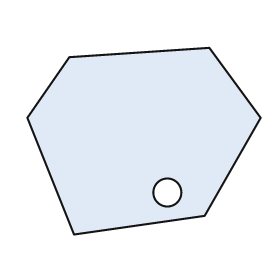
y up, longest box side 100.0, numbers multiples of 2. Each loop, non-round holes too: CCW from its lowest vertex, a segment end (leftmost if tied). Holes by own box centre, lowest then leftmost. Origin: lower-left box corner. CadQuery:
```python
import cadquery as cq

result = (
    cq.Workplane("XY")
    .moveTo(20.0, 0.0)
    .lineTo(76.0, 8.0)
    .lineTo(100.0, 50.0)
    .lineTo(78.0, 80.0)
    .lineTo(18.0, 76.0)
    .lineTo(0.0, 50.0)
    .close()
    .moveTo(60.0, 18.0)
    .circle(6.0)
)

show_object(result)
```